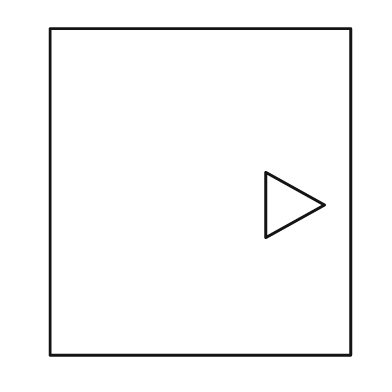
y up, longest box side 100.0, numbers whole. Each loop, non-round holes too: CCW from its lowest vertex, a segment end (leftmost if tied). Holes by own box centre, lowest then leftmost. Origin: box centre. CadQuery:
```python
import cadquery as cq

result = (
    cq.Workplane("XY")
    .moveTo(-46.0, -50.0)
    .lineTo(46.0, -50.0)
    .lineTo(46.0, 50.0)
    .lineTo(-46.0, 50.0)
    .close()
    .moveTo(20.0, -14.0)
    .lineTo(38.0, -4.0)
    .lineTo(20.0, 6.0)
    .close()
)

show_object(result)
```